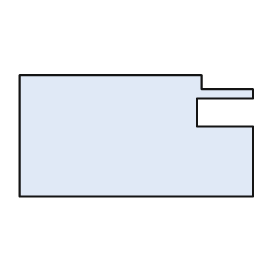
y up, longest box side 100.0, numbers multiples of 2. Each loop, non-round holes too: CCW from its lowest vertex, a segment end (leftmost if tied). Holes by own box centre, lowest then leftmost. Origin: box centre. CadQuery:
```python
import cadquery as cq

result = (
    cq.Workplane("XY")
    .moveTo(-50.0, -26.0)
    .lineTo(50.0, -26.0)
    .lineTo(50.0, 4.0)
    .lineTo(26.0, 4.0)
    .lineTo(26.0, 16.0)
    .lineTo(50.0, 16.0)
    .lineTo(50.0, 20.0)
    .lineTo(28.0, 20.0)
    .lineTo(28.0, 26.0)
    .lineTo(-50.0, 26.0)
    .close()
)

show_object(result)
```